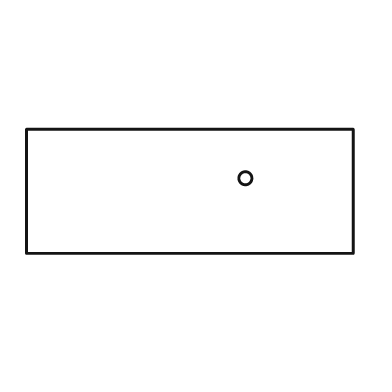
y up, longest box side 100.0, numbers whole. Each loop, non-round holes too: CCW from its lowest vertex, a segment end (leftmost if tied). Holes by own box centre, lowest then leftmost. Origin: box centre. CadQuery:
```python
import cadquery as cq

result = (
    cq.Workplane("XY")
    .moveTo(-50.0, -19.0)
    .lineTo(50.0, -19.0)
    .lineTo(50.0, 19.0)
    .lineTo(-50.0, 19.0)
    .close()
    .moveTo(17.0, 4.0)
    .circle(2.0)
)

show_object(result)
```